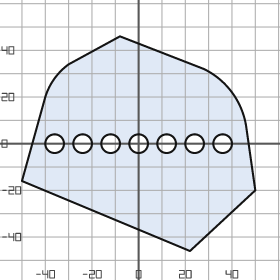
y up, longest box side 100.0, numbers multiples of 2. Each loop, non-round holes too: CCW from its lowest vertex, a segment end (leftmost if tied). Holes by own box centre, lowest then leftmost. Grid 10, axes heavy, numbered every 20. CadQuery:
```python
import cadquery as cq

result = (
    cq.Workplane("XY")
    .moveTo(22.0, -46.0)
    .lineTo(50.0, -20.0)
    .lineTo(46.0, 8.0)
    .threePointArc((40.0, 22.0), (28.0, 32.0))
    .lineTo(-8.0, 46.0)
    .lineTo(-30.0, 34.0)
    .threePointArc((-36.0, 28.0), (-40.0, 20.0))
    .lineTo(-50.0, -16.0)
    .close()
    .moveTo(-36.0, 0.0)
    .circle(4.0)
    .moveTo(-24.0, 0.0)
    .circle(4.0)
    .moveTo(-12.0, 0.0)
    .circle(4.0)
    .moveTo(0.0, 0.0)
    .circle(4.0)
    .moveTo(12.0, 0.0)
    .circle(4.0)
    .moveTo(24.0, 0.0)
    .circle(4.0)
    .moveTo(36.0, 0.0)
    .circle(4.0)
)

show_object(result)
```